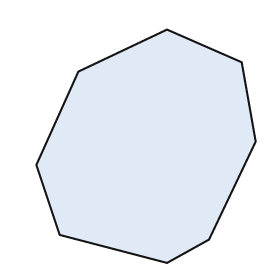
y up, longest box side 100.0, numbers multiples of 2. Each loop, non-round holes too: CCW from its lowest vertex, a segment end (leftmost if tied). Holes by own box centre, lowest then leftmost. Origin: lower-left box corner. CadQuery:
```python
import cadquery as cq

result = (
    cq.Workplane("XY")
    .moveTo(56.0, 0.0)
    .lineTo(74.0, 10.0)
    .lineTo(94.0, 52.0)
    .lineTo(88.0, 86.0)
    .lineTo(56.0, 100.0)
    .lineTo(18.0, 82.0)
    .lineTo(0.0, 42.0)
    .lineTo(10.0, 12.0)
    .close()
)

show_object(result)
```